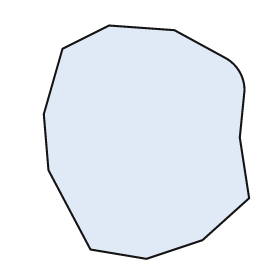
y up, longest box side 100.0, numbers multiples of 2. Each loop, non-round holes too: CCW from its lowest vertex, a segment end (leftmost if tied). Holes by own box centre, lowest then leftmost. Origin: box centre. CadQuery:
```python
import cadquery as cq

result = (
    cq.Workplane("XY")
    .moveTo(0.0, -50.0)
    .lineTo(24.0, -42.0)
    .lineTo(44.0, -24.0)
    .lineTo(40.0, 2.0)
    .lineTo(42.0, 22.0)
    .threePointArc((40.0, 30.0), (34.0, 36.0))
    .lineTo(12.0, 48.0)
    .lineTo(-16.0, 50.0)
    .lineTo(-36.0, 40.0)
    .lineTo(-44.0, 12.0)
    .lineTo(-42.0, -12.0)
    .lineTo(-24.0, -46.0)
    .close()
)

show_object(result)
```